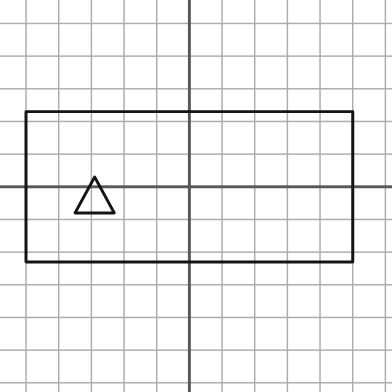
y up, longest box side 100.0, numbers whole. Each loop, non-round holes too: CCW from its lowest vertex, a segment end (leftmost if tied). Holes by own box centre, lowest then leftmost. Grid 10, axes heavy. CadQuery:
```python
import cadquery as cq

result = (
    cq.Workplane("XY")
    .moveTo(-50.0, -23.0)
    .lineTo(50.0, -23.0)
    .lineTo(50.0, 23.0)
    .lineTo(-50.0, 23.0)
    .close()
    .moveTo(-35.0, -8.0)
    .lineTo(-23.0, -8.0)
    .lineTo(-29.0, 3.0)
    .close()
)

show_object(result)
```